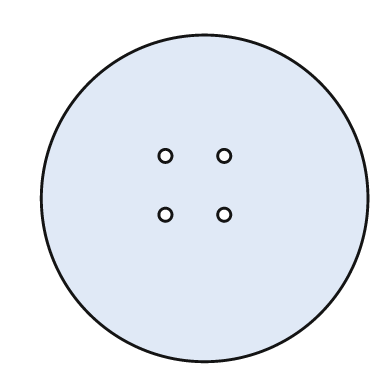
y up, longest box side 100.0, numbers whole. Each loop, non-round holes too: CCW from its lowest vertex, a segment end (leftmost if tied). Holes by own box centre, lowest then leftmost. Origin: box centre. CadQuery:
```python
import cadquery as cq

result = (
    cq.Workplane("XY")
    .moveTo(0.0, 0.0)
    .circle(50.0)
    .moveTo(-12.0, -5.0)
    .circle(2.0)
    .moveTo(6.0, -5.0)
    .circle(2.0)
    .moveTo(-12.0, 13.0)
    .circle(2.0)
    .moveTo(6.0, 13.0)
    .circle(2.0)
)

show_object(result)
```